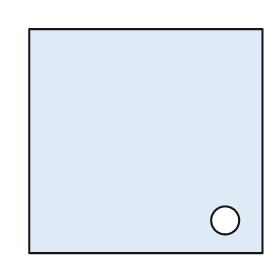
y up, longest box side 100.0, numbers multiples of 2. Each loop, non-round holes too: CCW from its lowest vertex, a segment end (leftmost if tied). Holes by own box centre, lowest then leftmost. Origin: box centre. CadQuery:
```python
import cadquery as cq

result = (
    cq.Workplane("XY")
    .moveTo(-50.0, -48.0)
    .lineTo(50.0, -48.0)
    .lineTo(50.0, 48.0)
    .lineTo(-50.0, 48.0)
    .close()
    .moveTo(34.0, -34.0)
    .circle(6.0)
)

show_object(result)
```